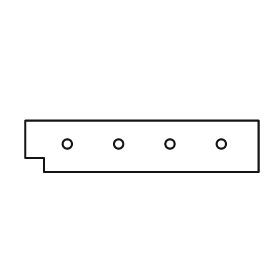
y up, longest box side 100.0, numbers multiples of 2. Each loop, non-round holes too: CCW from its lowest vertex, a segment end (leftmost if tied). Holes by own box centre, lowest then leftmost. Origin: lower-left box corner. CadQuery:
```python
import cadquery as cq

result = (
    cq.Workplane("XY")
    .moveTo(8.0, 0.0)
    .lineTo(100.0, 0.0)
    .lineTo(100.0, 22.0)
    .lineTo(0.0, 22.0)
    .lineTo(0.0, 6.0)
    .lineTo(8.0, 6.0)
    .close()
    .moveTo(18.0, 12.0)
    .circle(2.0)
    .moveTo(40.0, 12.0)
    .circle(2.0)
    .moveTo(62.0, 12.0)
    .circle(2.0)
    .moveTo(84.0, 12.0)
    .circle(2.0)
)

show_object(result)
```